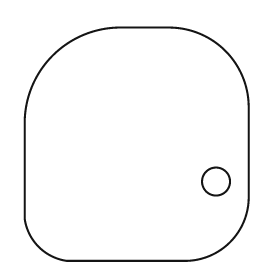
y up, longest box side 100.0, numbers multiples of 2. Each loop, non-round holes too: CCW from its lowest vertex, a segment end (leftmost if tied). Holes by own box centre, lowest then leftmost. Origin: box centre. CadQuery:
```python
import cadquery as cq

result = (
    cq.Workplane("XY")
    .moveTo(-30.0, -50.0)
    .lineTo(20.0, -50.0)
    .threePointArc((40.0, -42.0), (48.0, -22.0))
    .lineTo(48.0, 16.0)
    .threePointArc((38.0, 40.0), (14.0, 50.0))
    .lineTo(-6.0, 50.0)
    .threePointArc((-36.0, 38.0), (-48.0, 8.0))
    .lineTo(-48.0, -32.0)
    .threePointArc((-42.0, -44.0), (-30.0, -50.0))
    .close()
    .moveTo(34.0, -16.0)
    .circle(6.0)
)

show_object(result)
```